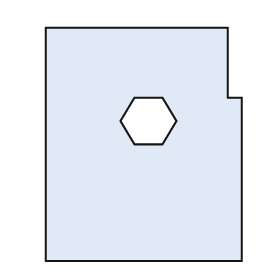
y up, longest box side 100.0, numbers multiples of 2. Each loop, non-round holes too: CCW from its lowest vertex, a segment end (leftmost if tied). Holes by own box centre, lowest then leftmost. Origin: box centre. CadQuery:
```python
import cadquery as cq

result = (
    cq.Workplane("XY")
    .moveTo(-42.0, -50.0)
    .lineTo(42.0, -50.0)
    .lineTo(42.0, 20.0)
    .lineTo(36.0, 20.0)
    .lineTo(36.0, 50.0)
    .lineTo(-42.0, 50.0)
    .close()
    .moveTo(-4.0, 0.0)
    .lineTo(8.0, 0.0)
    .lineTo(14.0, 10.0)
    .lineTo(8.0, 20.0)
    .lineTo(-4.0, 20.0)
    .lineTo(-10.0, 10.0)
    .close()
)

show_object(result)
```